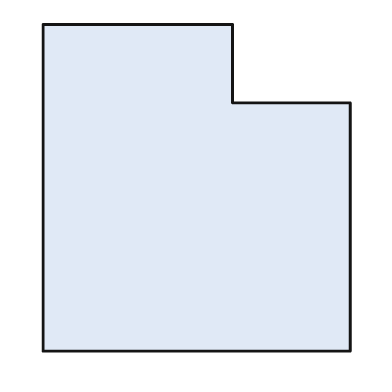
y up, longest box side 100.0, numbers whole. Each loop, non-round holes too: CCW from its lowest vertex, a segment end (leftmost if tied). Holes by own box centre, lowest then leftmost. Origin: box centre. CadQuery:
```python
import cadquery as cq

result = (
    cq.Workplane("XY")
    .moveTo(-47.0, -50.0)
    .lineTo(47.0, -50.0)
    .lineTo(47.0, 26.0)
    .lineTo(11.0, 26.0)
    .lineTo(11.0, 50.0)
    .lineTo(-47.0, 50.0)
    .close()
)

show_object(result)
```